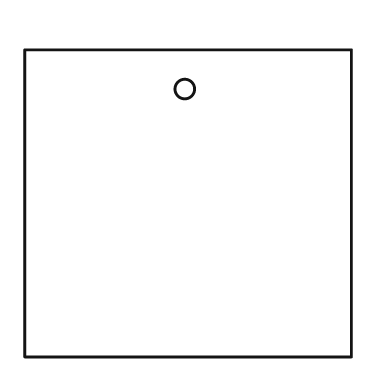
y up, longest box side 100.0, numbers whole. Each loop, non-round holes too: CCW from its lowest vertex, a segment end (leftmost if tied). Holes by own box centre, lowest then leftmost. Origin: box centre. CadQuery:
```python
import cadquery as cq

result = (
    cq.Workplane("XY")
    .moveTo(-50.0, -47.0)
    .lineTo(50.0, -47.0)
    .lineTo(50.0, 47.0)
    .lineTo(-50.0, 47.0)
    .close()
    .moveTo(-1.0, 35.0)
    .circle(3.0)
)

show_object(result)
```